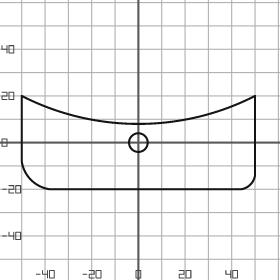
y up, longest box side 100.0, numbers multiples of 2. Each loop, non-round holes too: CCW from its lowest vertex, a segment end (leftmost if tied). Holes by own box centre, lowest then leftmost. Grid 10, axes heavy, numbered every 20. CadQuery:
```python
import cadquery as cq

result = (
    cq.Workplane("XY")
    .moveTo(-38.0, -20.0)
    .lineTo(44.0, -20.0)
    .threePointArc((48.0, -18.0), (50.0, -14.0))
    .lineTo(50.0, 20.0)
    .threePointArc((0.0, 8.0), (-50.0, 20.0))
    .lineTo(-50.0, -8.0)
    .threePointArc((-46.0, -16.0), (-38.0, -20.0))
    .close()
    .moveTo(0.0, 0.0)
    .circle(4.0)
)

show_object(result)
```